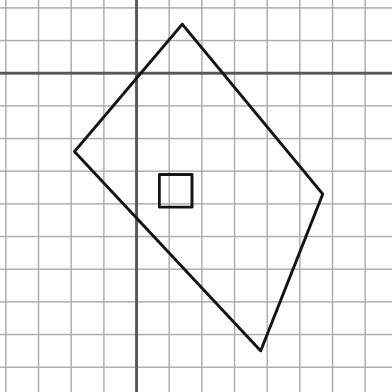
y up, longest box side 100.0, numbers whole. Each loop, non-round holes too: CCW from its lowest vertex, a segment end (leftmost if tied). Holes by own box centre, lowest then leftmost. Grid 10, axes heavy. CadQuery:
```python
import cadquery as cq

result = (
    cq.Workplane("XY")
    .moveTo(38.0, -85.0)
    .lineTo(57.0, -37.0)
    .lineTo(14.0, 15.0)
    .lineTo(-19.0, -24.0)
    .close()
    .moveTo(7.0, -41.0)
    .lineTo(17.0, -41.0)
    .lineTo(17.0, -31.0)
    .lineTo(7.0, -31.0)
    .close()
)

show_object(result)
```